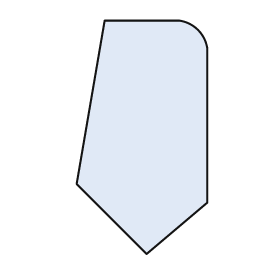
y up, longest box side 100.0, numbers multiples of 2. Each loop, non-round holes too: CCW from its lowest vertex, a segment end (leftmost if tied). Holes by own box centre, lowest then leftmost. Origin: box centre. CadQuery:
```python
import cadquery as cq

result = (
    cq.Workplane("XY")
    .moveTo(2.0, -50.0)
    .lineTo(28.0, -28.0)
    .lineTo(28.0, 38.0)
    .threePointArc((24.0, 46.0), (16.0, 50.0))
    .lineTo(-16.0, 50.0)
    .lineTo(-28.0, -20.0)
    .close()
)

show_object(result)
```